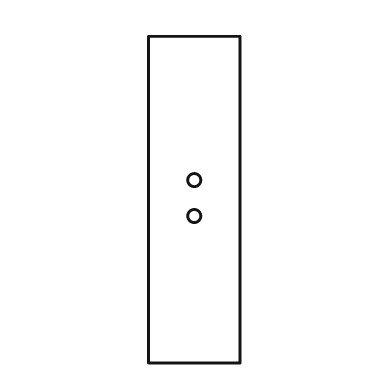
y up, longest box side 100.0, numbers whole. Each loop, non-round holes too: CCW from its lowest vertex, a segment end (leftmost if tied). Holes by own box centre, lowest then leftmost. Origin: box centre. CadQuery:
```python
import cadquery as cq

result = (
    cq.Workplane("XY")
    .moveTo(-14.0, -50.0)
    .lineTo(14.0, -50.0)
    .lineTo(14.0, 50.0)
    .lineTo(-14.0, 50.0)
    .close()
    .moveTo(0.0, -5.0)
    .circle(2.0)
    .moveTo(0.0, 6.0)
    .circle(2.0)
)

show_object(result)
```